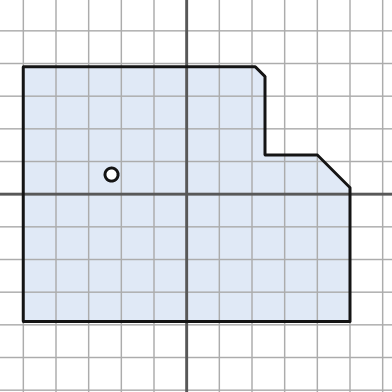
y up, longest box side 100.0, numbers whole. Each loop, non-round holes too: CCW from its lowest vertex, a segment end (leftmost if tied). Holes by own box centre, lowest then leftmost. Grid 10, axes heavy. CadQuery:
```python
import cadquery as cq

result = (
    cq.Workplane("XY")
    .moveTo(-50.0, -39.0)
    .lineTo(50.0, -39.0)
    .lineTo(50.0, 2.0)
    .lineTo(40.0, 12.0)
    .lineTo(24.0, 12.0)
    .lineTo(24.0, 36.0)
    .lineTo(21.0, 39.0)
    .lineTo(-50.0, 39.0)
    .close()
    .moveTo(-23.0, 6.0)
    .circle(2.0)
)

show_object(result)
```